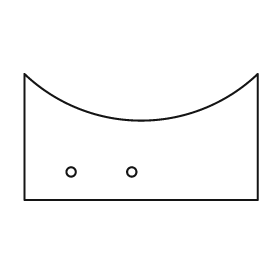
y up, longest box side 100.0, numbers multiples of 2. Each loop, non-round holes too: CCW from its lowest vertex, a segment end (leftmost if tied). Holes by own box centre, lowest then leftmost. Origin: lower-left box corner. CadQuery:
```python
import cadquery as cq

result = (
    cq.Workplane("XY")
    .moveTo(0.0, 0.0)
    .lineTo(100.0, 0.0)
    .lineTo(100.0, 54.0)
    .threePointArc((50.0, 34.0), (0.0, 54.0))
    .close()
    .moveTo(20.0, 12.0)
    .circle(2.0)
    .moveTo(46.0, 12.0)
    .circle(2.0)
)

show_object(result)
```